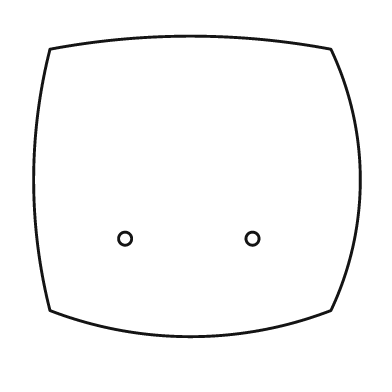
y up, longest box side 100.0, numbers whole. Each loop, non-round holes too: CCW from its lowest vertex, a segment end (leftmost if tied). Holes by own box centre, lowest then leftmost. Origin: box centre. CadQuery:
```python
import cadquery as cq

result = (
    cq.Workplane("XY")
    .moveTo(-45.0, -38.0)
    .threePointArc((-2.0, -46.0), (41.0, -38.0))
    .threePointArc((50.0, 2.0), (41.0, 42.0))
    .threePointArc((-2.0, 46.0), (-45.0, 42.0))
    .threePointArc((-50.0, 2.0), (-45.0, -38.0))
    .close()
    .moveTo(-22.0, -16.0)
    .circle(2.0)
    .moveTo(17.0, -16.0)
    .circle(2.0)
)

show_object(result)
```